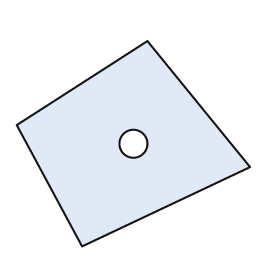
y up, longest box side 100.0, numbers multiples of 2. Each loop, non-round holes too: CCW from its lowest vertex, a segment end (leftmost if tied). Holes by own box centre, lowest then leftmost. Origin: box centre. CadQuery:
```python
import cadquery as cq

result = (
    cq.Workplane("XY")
    .moveTo(-22.0, -44.0)
    .lineTo(50.0, -10.0)
    .lineTo(6.0, 44.0)
    .lineTo(-50.0, 8.0)
    .close()
    .moveTo(0.0, 0.0)
    .circle(6.0)
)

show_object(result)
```